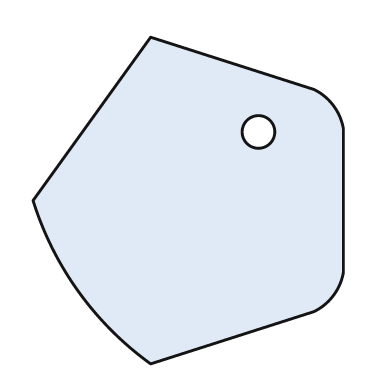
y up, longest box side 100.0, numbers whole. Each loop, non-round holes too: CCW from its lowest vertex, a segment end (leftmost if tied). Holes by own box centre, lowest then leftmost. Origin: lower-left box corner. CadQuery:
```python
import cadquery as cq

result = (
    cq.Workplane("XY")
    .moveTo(36.0, 0.0)
    .lineTo(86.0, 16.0)
    .threePointArc((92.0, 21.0), (95.0, 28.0))
    .lineTo(95.0, 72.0)
    .threePointArc((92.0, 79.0), (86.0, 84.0))
    .lineTo(36.0, 100.0)
    .lineTo(0.0, 50.0)
    .threePointArc((14.0, 22.0), (36.0, 0.0))
    .close()
    .moveTo(69.0, 71.0)
    .circle(5.0)
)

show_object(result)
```